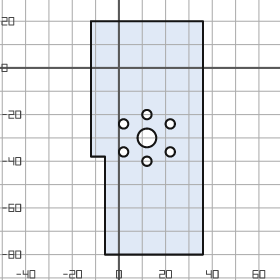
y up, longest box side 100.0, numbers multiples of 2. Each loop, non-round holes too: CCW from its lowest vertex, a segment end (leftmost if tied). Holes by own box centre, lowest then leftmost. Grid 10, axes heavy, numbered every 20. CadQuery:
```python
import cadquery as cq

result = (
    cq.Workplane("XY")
    .moveTo(-6.0, -80.0)
    .lineTo(36.0, -80.0)
    .lineTo(36.0, 20.0)
    .lineTo(-12.0, 20.0)
    .lineTo(-12.0, -38.0)
    .lineTo(-6.0, -38.0)
    .close()
    .moveTo(12.0, -40.0)
    .circle(2.0)
    .moveTo(2.0, -36.0)
    .circle(2.0)
    .moveTo(22.0, -36.0)
    .circle(2.0)
    .moveTo(12.0, -30.0)
    .circle(4.0)
    .moveTo(2.0, -24.0)
    .circle(2.0)
    .moveTo(22.0, -24.0)
    .circle(2.0)
    .moveTo(12.0, -20.0)
    .circle(2.0)
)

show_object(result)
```